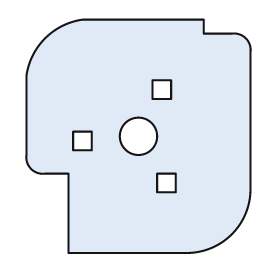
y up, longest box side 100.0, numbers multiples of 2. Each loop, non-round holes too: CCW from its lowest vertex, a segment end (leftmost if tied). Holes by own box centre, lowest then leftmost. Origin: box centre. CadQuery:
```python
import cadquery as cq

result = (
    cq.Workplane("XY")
    .moveTo(-30.0, -50.0)
    .lineTo(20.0, -50.0)
    .threePointArc((40.0, -42.0), (48.0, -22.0))
    .lineTo(48.0, 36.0)
    .threePointArc((46.0, 42.0), (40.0, 44.0))
    .lineTo(28.0, 44.0)
    .lineTo(28.0, 50.0)
    .lineTo(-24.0, 50.0)
    .threePointArc((-40.0, 42.0), (-48.0, 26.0))
    .lineTo(-48.0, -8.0)
    .threePointArc((-46.0, -14.0), (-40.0, -16.0))
    .lineTo(-30.0, -16.0)
    .close()
    .moveTo(8.0, -24.0)
    .lineTo(16.0, -24.0)
    .lineTo(16.0, -16.0)
    .lineTo(8.0, -16.0)
    .close()
    .moveTo(-28.0, -6.0)
    .lineTo(-20.0, -6.0)
    .lineTo(-20.0, 2.0)
    .lineTo(-28.0, 2.0)
    .close()
    .moveTo(0.0, 0.0)
    .circle(8.0)
    .moveTo(6.0, 16.0)
    .lineTo(14.0, 16.0)
    .lineTo(14.0, 24.0)
    .lineTo(6.0, 24.0)
    .close()
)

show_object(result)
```